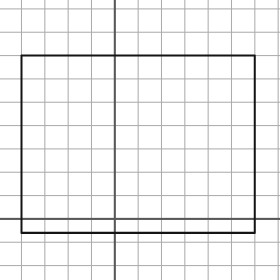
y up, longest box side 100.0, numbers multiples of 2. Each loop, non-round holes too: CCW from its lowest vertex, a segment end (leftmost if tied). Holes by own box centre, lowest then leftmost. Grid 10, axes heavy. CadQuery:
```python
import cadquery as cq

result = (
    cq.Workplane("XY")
    .moveTo(-40.0, -6.0)
    .lineTo(60.0, -6.0)
    .lineTo(60.0, 70.0)
    .lineTo(-40.0, 70.0)
    .close()
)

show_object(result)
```